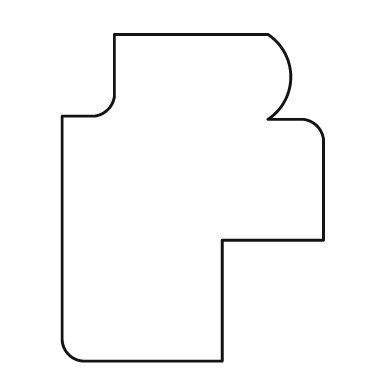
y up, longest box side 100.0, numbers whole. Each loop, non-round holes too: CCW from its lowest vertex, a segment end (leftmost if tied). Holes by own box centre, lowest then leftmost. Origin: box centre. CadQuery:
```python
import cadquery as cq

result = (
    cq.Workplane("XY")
    .moveTo(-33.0, -50.0)
    .lineTo(9.0, -50.0)
    .lineTo(9.0, -13.0)
    .lineTo(40.0, -13.0)
    .lineTo(40.0, 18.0)
    .threePointArc((38.0, 22.0), (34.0, 24.0))
    .lineTo(23.0, 24.0)
    .threePointArc((30.0, 37.0), (23.0, 50.0))
    .lineTo(-24.0, 50.0)
    .lineTo(-24.0, 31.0)
    .threePointArc((-26.0, 27.0), (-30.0, 25.0))
    .lineTo(-40.0, 25.0)
    .lineTo(-40.0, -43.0)
    .threePointArc((-38.0, -48.0), (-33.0, -50.0))
    .close()
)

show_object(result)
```